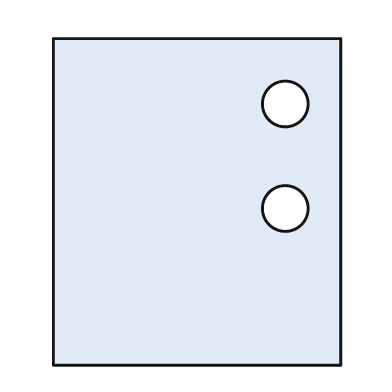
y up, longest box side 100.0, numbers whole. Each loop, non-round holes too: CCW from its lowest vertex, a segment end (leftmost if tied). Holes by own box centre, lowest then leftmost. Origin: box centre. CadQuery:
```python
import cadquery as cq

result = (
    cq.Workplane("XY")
    .moveTo(-44.0, -50.0)
    .lineTo(44.0, -50.0)
    .lineTo(44.0, 50.0)
    .lineTo(-44.0, 50.0)
    .close()
    .moveTo(27.0, -2.0)
    .circle(7.0)
    .moveTo(27.0, 30.0)
    .circle(7.0)
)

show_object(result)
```